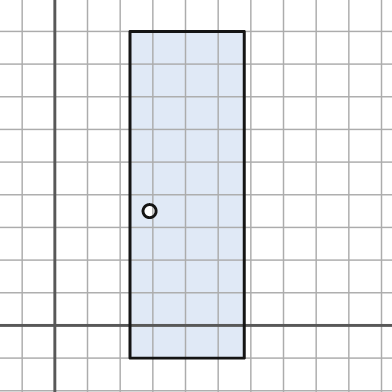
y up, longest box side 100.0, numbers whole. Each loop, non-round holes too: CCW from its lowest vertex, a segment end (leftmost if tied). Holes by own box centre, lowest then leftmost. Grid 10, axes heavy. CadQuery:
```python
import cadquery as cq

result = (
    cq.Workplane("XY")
    .moveTo(23.0, -10.0)
    .lineTo(58.0, -10.0)
    .lineTo(58.0, 90.0)
    .lineTo(23.0, 90.0)
    .close()
    .moveTo(29.0, 35.0)
    .circle(2.0)
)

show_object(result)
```